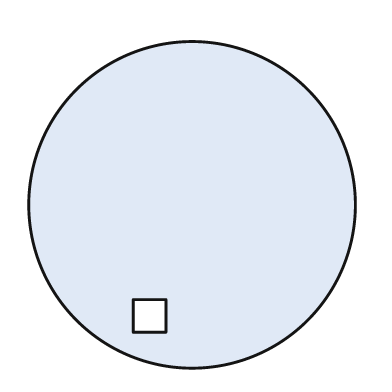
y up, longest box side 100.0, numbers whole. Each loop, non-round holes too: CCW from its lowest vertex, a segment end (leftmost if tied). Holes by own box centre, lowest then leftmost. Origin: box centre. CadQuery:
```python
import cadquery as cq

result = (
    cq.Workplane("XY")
    .moveTo(0.0, 0.0)
    .circle(50.0)
    .moveTo(-18.0, -39.0)
    .lineTo(-8.0, -39.0)
    .lineTo(-8.0, -29.0)
    .lineTo(-18.0, -29.0)
    .close()
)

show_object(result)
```